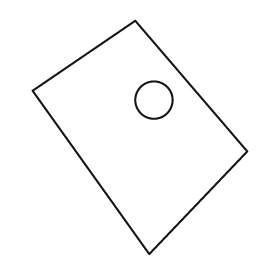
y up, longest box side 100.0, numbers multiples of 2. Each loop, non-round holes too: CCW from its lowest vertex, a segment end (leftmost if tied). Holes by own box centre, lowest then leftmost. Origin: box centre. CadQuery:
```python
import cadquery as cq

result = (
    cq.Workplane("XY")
    .moveTo(4.0, -50.0)
    .lineTo(46.0, -6.0)
    .lineTo(-2.0, 50.0)
    .lineTo(-46.0, 20.0)
    .close()
    .moveTo(6.0, 16.0)
    .circle(8.0)
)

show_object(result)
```